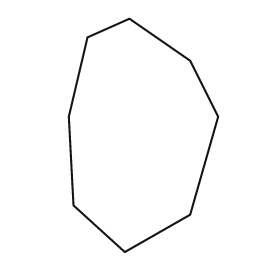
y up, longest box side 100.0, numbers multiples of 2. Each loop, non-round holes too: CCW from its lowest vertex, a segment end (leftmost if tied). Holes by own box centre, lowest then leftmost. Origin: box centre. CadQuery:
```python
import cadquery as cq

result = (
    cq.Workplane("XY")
    .moveTo(-8.0, -50.0)
    .lineTo(20.0, -34.0)
    .lineTo(32.0, 8.0)
    .lineTo(20.0, 32.0)
    .lineTo(-6.0, 50.0)
    .lineTo(-24.0, 42.0)
    .lineTo(-32.0, 8.0)
    .lineTo(-30.0, -30.0)
    .close()
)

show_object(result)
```